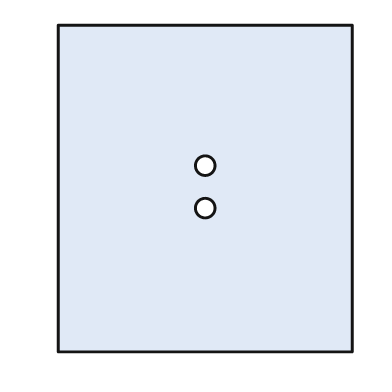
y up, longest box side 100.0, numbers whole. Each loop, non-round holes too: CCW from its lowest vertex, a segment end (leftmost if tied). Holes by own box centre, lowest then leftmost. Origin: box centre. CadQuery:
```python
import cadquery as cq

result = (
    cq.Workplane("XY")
    .moveTo(-45.0, -50.0)
    .lineTo(45.0, -50.0)
    .lineTo(45.0, 50.0)
    .lineTo(-45.0, 50.0)
    .close()
    .moveTo(0.0, -6.0)
    .circle(3.0)
    .moveTo(0.0, 7.0)
    .circle(3.0)
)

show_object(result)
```